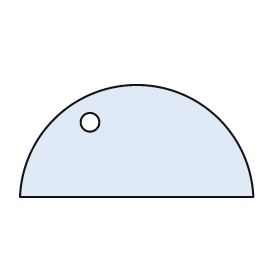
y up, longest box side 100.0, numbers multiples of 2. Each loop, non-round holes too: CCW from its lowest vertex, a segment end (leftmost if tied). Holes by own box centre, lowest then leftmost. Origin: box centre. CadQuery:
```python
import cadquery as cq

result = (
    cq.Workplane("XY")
    .moveTo(-50.0, -24.0)
    .lineTo(50.0, -24.0)
    .threePointArc((0.0, 24.0), (-50.0, -24.0))
    .close()
    .moveTo(-20.0, 8.0)
    .circle(4.0)
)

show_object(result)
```